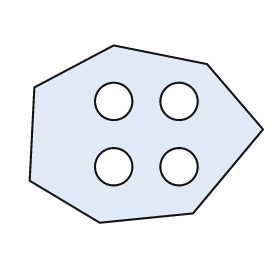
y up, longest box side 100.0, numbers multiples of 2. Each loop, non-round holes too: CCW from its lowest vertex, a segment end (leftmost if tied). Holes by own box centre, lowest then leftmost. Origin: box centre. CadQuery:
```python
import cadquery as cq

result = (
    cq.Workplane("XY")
    .moveTo(-20.0, -38.0)
    .lineTo(20.0, -34.0)
    .lineTo(50.0, 2.0)
    .lineTo(26.0, 30.0)
    .lineTo(-14.0, 38.0)
    .lineTo(-48.0, 20.0)
    .lineTo(-50.0, -20.0)
    .close()
    .moveTo(-14.0, -14.0)
    .circle(8.0)
    .moveTo(14.0, -14.0)
    .circle(8.0)
    .moveTo(-14.0, 14.0)
    .circle(8.0)
    .moveTo(14.0, 14.0)
    .circle(8.0)
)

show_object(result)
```